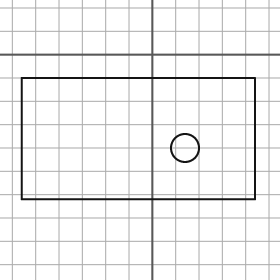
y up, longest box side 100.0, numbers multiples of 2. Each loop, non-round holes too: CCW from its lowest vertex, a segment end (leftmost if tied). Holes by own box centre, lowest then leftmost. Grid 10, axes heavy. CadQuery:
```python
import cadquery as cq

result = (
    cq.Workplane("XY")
    .moveTo(-56.0, -62.0)
    .lineTo(44.0, -62.0)
    .lineTo(44.0, -10.0)
    .lineTo(-56.0, -10.0)
    .close()
    .moveTo(14.0, -40.0)
    .circle(6.0)
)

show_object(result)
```